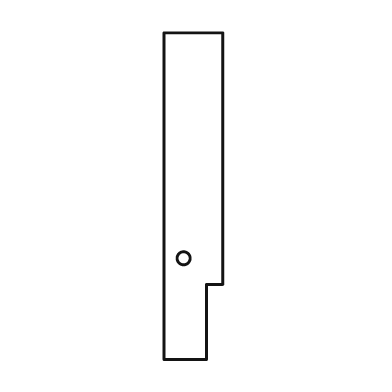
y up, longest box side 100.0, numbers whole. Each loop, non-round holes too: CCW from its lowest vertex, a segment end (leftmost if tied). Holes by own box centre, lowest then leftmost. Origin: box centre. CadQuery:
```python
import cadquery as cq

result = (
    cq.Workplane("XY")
    .moveTo(-9.0, -50.0)
    .lineTo(4.0, -50.0)
    .lineTo(4.0, -27.0)
    .lineTo(9.0, -27.0)
    .lineTo(9.0, 50.0)
    .lineTo(-9.0, 50.0)
    .close()
    .moveTo(-3.0, -19.0)
    .circle(2.0)
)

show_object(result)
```